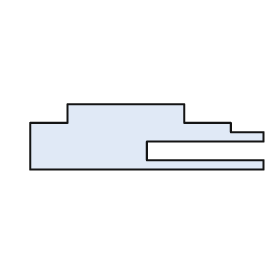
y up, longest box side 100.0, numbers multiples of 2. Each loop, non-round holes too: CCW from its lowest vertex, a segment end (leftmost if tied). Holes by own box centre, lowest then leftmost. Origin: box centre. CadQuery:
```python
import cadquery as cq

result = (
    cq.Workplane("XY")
    .moveTo(-50.0, -14.0)
    .lineTo(50.0, -14.0)
    .lineTo(50.0, -10.0)
    .lineTo(0.0, -10.0)
    .lineTo(0.0, -2.0)
    .lineTo(50.0, -2.0)
    .lineTo(50.0, 2.0)
    .lineTo(36.0, 2.0)
    .lineTo(36.0, 6.0)
    .lineTo(16.0, 6.0)
    .lineTo(16.0, 14.0)
    .lineTo(-34.0, 14.0)
    .lineTo(-34.0, 6.0)
    .lineTo(-50.0, 6.0)
    .close()
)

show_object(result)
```